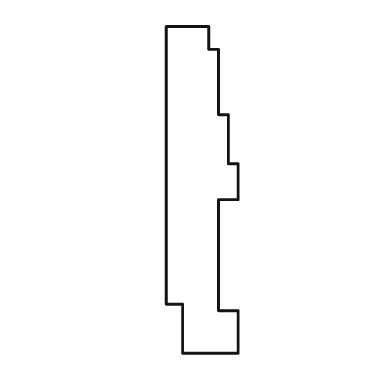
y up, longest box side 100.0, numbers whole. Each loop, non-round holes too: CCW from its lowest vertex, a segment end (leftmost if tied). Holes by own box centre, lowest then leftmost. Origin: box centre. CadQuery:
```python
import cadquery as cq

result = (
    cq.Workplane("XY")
    .moveTo(-6.0, -50.0)
    .lineTo(11.0, -50.0)
    .lineTo(11.0, -37.0)
    .lineTo(5.0, -37.0)
    .lineTo(5.0, -3.0)
    .lineTo(11.0, -3.0)
    .lineTo(11.0, 8.0)
    .lineTo(8.0, 8.0)
    .lineTo(8.0, 23.0)
    .lineTo(5.0, 23.0)
    .lineTo(5.0, 43.0)
    .lineTo(2.0, 43.0)
    .lineTo(2.0, 50.0)
    .lineTo(-11.0, 50.0)
    .lineTo(-11.0, -35.0)
    .lineTo(-6.0, -35.0)
    .close()
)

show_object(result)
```